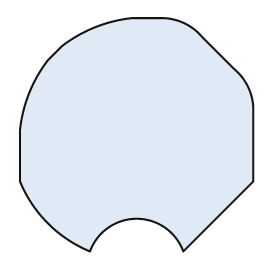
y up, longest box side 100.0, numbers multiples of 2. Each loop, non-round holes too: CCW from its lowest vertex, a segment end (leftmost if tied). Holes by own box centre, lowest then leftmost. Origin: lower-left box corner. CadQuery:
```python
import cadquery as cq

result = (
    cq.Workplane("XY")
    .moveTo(30.0, 0.0)
    .threePointArc((50.0, 14.0), (70.0, 0.0))
    .lineTo(100.0, 30.0)
    .lineTo(100.0, 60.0)
    .threePointArc((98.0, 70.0), (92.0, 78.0))
    .lineTo(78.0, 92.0)
    .threePointArc((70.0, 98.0), (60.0, 100.0))
    .lineTo(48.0, 100.0)
    .threePointArc((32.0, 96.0), (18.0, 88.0))
    .lineTo(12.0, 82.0)
    .threePointArc((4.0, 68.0), (0.0, 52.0))
    .lineTo(0.0, 30.0)
    .threePointArc((12.0, 12.0), (30.0, 0.0))
    .close()
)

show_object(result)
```